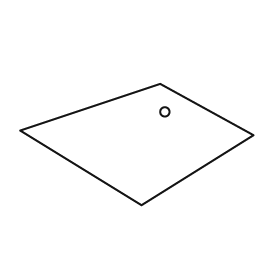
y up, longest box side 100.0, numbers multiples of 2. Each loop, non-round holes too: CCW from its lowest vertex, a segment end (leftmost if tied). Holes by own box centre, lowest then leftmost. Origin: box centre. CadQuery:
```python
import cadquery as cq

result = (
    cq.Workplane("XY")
    .moveTo(2.0, -26.0)
    .lineTo(50.0, 4.0)
    .lineTo(10.0, 26.0)
    .lineTo(-50.0, 6.0)
    .close()
    .moveTo(12.0, 14.0)
    .circle(2.0)
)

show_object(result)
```